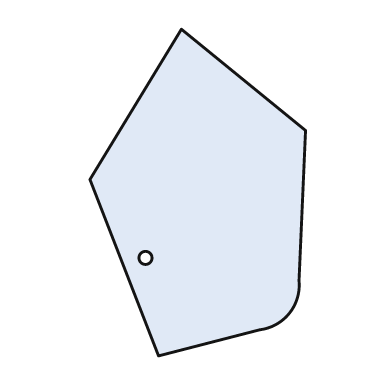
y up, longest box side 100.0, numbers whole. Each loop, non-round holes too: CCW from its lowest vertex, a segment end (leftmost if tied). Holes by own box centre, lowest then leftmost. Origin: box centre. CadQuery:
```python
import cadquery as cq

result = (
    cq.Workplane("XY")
    .moveTo(-12.0, -50.0)
    .lineTo(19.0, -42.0)
    .threePointArc((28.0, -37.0), (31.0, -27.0))
    .lineTo(33.0, 19.0)
    .lineTo(-5.0, 50.0)
    .lineTo(-33.0, 4.0)
    .close()
    .moveTo(-16.0, -20.0)
    .circle(2.0)
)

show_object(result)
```